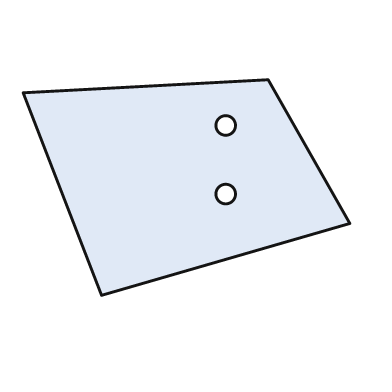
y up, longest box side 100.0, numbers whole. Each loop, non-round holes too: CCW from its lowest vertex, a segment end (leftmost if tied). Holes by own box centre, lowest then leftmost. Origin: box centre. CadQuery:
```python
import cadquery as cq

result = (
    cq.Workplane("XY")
    .moveTo(-26.0, -33.0)
    .lineTo(50.0, -11.0)
    .lineTo(25.0, 33.0)
    .lineTo(-50.0, 29.0)
    .close()
    .moveTo(12.0, -2.0)
    .circle(3.0)
    .moveTo(12.0, 19.0)
    .circle(3.0)
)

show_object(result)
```